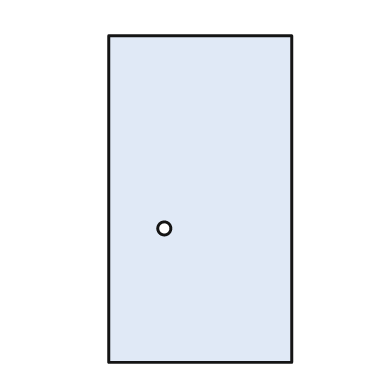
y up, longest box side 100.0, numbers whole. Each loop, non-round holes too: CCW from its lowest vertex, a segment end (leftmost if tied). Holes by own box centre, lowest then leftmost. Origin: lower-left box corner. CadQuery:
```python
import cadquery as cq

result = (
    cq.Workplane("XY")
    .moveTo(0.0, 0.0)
    .lineTo(56.0, 0.0)
    .lineTo(56.0, 100.0)
    .lineTo(0.0, 100.0)
    .close()
    .moveTo(17.0, 41.0)
    .circle(2.0)
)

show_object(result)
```